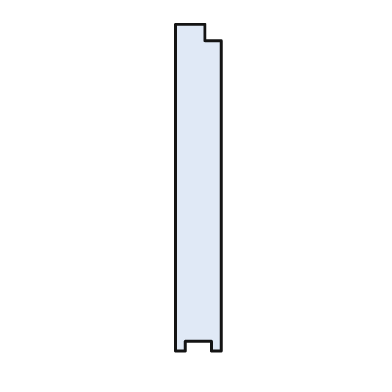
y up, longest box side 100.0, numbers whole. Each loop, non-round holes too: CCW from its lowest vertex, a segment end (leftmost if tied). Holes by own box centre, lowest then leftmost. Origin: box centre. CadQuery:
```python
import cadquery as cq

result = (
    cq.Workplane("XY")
    .moveTo(-7.0, -50.0)
    .lineTo(-4.0, -50.0)
    .lineTo(-4.0, -47.0)
    .lineTo(4.0, -47.0)
    .lineTo(4.0, -50.0)
    .lineTo(7.0, -50.0)
    .lineTo(7.0, 45.0)
    .lineTo(2.0, 45.0)
    .lineTo(2.0, 50.0)
    .lineTo(-7.0, 50.0)
    .close()
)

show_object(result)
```